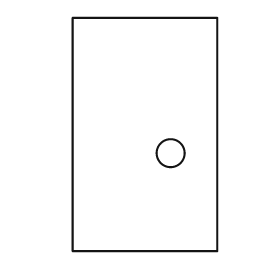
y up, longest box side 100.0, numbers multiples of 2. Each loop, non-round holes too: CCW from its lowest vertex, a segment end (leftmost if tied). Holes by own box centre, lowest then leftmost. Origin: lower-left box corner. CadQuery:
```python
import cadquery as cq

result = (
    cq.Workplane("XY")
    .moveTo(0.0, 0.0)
    .lineTo(62.0, 0.0)
    .lineTo(62.0, 100.0)
    .lineTo(0.0, 100.0)
    .close()
    .moveTo(42.0, 42.0)
    .circle(6.0)
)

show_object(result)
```